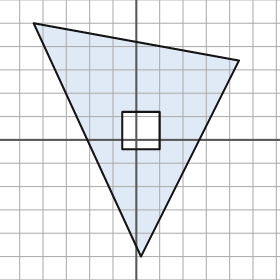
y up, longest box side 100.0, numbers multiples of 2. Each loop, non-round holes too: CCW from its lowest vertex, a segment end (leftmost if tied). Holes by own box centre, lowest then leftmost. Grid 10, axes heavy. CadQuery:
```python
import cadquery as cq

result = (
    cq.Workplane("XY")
    .moveTo(2.0, -50.0)
    .lineTo(44.0, 34.0)
    .lineTo(-44.0, 50.0)
    .close()
    .moveTo(-6.0, -4.0)
    .lineTo(10.0, -4.0)
    .lineTo(10.0, 12.0)
    .lineTo(-6.0, 12.0)
    .close()
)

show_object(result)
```